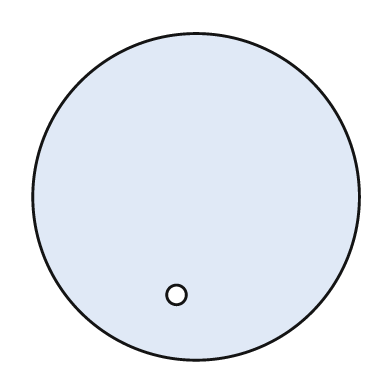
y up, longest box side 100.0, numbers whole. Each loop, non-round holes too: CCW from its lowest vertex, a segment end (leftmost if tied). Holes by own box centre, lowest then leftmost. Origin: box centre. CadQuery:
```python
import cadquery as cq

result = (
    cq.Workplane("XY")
    .moveTo(0.0, 0.0)
    .circle(50.0)
    .moveTo(-6.0, -30.0)
    .circle(3.0)
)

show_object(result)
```